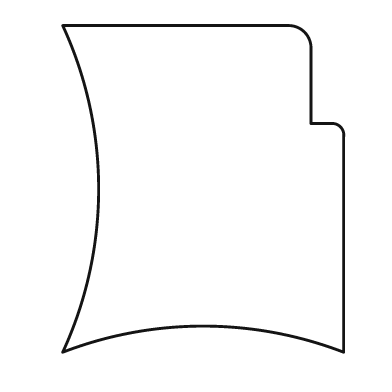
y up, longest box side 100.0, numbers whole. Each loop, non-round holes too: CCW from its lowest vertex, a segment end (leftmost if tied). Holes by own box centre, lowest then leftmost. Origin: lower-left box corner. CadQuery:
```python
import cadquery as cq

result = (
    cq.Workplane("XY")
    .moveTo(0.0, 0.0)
    .threePointArc((43.0, 8.0), (86.0, 0.0))
    .lineTo(86.0, 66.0)
    .threePointArc((85.0, 69.0), (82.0, 70.0))
    .lineTo(76.0, 70.0)
    .lineTo(76.0, 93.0)
    .threePointArc((74.0, 98.0), (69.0, 100.0))
    .lineTo(0.0, 100.0)
    .threePointArc((11.0, 50.0), (0.0, 0.0))
    .close()
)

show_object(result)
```